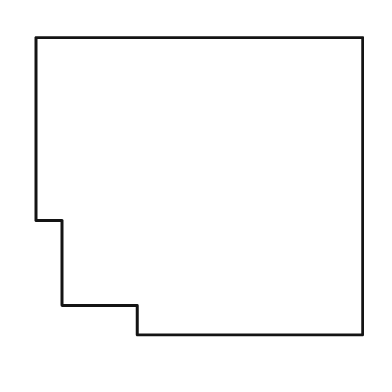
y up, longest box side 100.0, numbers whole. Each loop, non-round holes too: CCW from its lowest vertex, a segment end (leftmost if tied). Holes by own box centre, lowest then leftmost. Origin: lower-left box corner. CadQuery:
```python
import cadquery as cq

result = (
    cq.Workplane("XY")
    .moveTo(31.0, 0.0)
    .lineTo(100.0, 0.0)
    .lineTo(100.0, 91.0)
    .lineTo(0.0, 91.0)
    .lineTo(0.0, 35.0)
    .lineTo(8.0, 35.0)
    .lineTo(8.0, 9.0)
    .lineTo(31.0, 9.0)
    .close()
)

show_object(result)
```